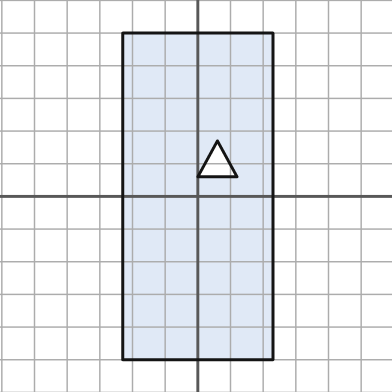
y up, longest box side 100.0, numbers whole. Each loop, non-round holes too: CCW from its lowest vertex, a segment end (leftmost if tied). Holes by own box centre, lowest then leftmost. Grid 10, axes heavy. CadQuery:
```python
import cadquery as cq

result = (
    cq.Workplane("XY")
    .moveTo(-23.0, -50.0)
    .lineTo(23.0, -50.0)
    .lineTo(23.0, 50.0)
    .lineTo(-23.0, 50.0)
    .close()
    .moveTo(0.0, 6.0)
    .lineTo(12.0, 6.0)
    .lineTo(6.0, 17.0)
    .close()
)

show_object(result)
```